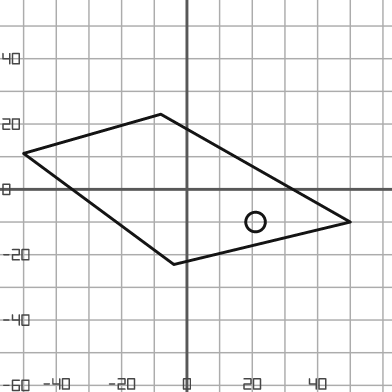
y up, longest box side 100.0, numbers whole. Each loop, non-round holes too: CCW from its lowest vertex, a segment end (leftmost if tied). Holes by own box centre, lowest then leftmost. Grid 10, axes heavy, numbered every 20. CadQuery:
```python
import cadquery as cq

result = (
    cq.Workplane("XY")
    .moveTo(-4.0, -23.0)
    .lineTo(50.0, -10.0)
    .lineTo(-8.0, 23.0)
    .lineTo(-50.0, 11.0)
    .close()
    .moveTo(21.0, -10.0)
    .circle(3.0)
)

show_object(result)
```